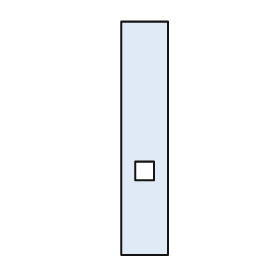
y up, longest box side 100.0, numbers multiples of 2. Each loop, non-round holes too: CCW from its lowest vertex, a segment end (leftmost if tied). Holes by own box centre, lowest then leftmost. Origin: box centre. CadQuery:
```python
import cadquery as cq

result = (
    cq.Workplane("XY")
    .moveTo(-10.0, -50.0)
    .lineTo(10.0, -50.0)
    .lineTo(10.0, 50.0)
    .lineTo(-10.0, 50.0)
    .close()
    .moveTo(-4.0, -18.0)
    .lineTo(4.0, -18.0)
    .lineTo(4.0, -10.0)
    .lineTo(-4.0, -10.0)
    .close()
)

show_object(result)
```